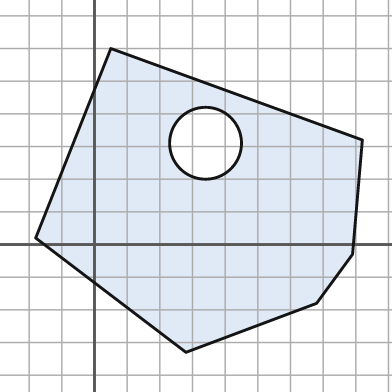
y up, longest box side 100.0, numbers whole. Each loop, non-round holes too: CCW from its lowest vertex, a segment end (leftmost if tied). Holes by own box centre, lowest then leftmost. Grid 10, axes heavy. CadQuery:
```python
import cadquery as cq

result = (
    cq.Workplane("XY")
    .moveTo(28.0, -33.0)
    .lineTo(68.0, -18.0)
    .lineTo(79.0, -3.0)
    .lineTo(82.0, 32.0)
    .lineTo(5.0, 60.0)
    .lineTo(-18.0, 2.0)
    .close()
    .moveTo(34.0, 31.0)
    .circle(11.0)
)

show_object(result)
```